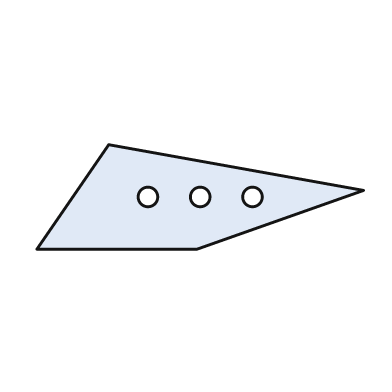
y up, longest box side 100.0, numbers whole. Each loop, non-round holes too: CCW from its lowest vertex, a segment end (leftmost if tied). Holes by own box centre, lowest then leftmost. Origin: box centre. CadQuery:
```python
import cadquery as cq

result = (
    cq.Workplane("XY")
    .moveTo(-50.0, -16.0)
    .lineTo(-1.0, -16.0)
    .lineTo(50.0, 2.0)
    .lineTo(-28.0, 16.0)
    .close()
    .moveTo(-16.0, 0.0)
    .circle(3.0)
    .moveTo(0.0, 0.0)
    .circle(3.0)
    .moveTo(16.0, 0.0)
    .circle(3.0)
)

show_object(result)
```